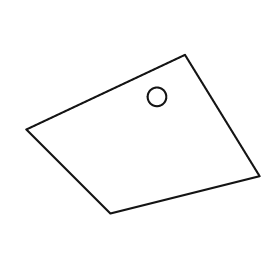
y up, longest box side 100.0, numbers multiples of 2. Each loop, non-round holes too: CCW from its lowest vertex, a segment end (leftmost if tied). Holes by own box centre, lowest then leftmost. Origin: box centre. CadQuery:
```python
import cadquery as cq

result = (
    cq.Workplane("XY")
    .moveTo(-14.0, -34.0)
    .lineTo(50.0, -18.0)
    .lineTo(18.0, 34.0)
    .lineTo(-50.0, 2.0)
    .close()
    .moveTo(6.0, 16.0)
    .circle(4.0)
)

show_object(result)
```